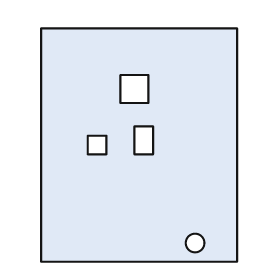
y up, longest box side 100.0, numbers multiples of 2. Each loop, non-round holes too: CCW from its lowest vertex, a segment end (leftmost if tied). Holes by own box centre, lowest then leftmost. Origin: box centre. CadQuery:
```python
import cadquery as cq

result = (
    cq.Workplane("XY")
    .moveTo(-42.0, -50.0)
    .lineTo(42.0, -50.0)
    .lineTo(42.0, 50.0)
    .lineTo(-42.0, 50.0)
    .close()
    .moveTo(24.0, -42.0)
    .circle(4.0)
    .moveTo(-22.0, -4.0)
    .lineTo(-14.0, -4.0)
    .lineTo(-14.0, 4.0)
    .lineTo(-22.0, 4.0)
    .close()
    .moveTo(-2.0, -4.0)
    .lineTo(6.0, -4.0)
    .lineTo(6.0, 8.0)
    .lineTo(-2.0, 8.0)
    .close()
    .moveTo(-8.0, 18.0)
    .lineTo(4.0, 18.0)
    .lineTo(4.0, 30.0)
    .lineTo(-8.0, 30.0)
    .close()
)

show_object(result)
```